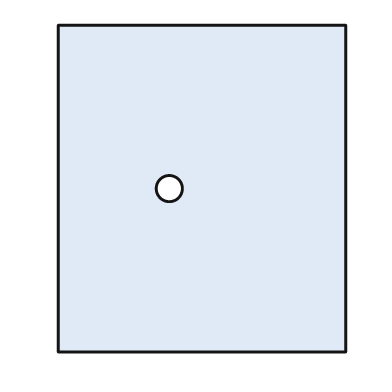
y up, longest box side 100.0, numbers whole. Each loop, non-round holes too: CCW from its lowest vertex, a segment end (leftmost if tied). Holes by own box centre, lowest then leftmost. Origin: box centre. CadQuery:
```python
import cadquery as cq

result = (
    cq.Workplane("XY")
    .moveTo(-44.0, -50.0)
    .lineTo(44.0, -50.0)
    .lineTo(44.0, 50.0)
    .lineTo(-44.0, 50.0)
    .close()
    .moveTo(-10.0, 0.0)
    .circle(4.0)
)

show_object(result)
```